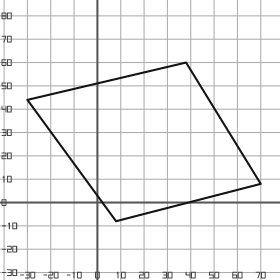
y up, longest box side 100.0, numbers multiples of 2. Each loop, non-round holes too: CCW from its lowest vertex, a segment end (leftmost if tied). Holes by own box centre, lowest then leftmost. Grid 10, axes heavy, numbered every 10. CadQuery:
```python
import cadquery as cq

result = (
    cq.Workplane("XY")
    .moveTo(8.0, -8.0)
    .lineTo(70.0, 8.0)
    .lineTo(38.0, 60.0)
    .lineTo(-30.0, 44.0)
    .close()
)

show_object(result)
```